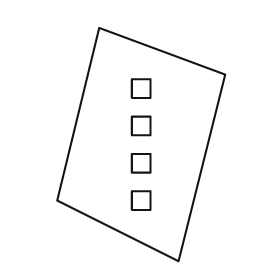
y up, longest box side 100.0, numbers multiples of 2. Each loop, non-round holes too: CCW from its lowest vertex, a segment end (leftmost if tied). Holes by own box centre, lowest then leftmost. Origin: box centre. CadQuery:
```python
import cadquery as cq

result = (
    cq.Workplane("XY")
    .moveTo(16.0, -50.0)
    .lineTo(36.0, 30.0)
    .lineTo(-18.0, 50.0)
    .lineTo(-36.0, -24.0)
    .close()
    .moveTo(-4.0, -28.0)
    .lineTo(4.0, -28.0)
    .lineTo(4.0, -20.0)
    .lineTo(-4.0, -20.0)
    .close()
    .moveTo(-4.0, -12.0)
    .lineTo(4.0, -12.0)
    .lineTo(4.0, -4.0)
    .lineTo(-4.0, -4.0)
    .close()
    .moveTo(-4.0, 4.0)
    .lineTo(4.0, 4.0)
    .lineTo(4.0, 12.0)
    .lineTo(-4.0, 12.0)
    .close()
    .moveTo(-4.0, 20.0)
    .lineTo(4.0, 20.0)
    .lineTo(4.0, 28.0)
    .lineTo(-4.0, 28.0)
    .close()
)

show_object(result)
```